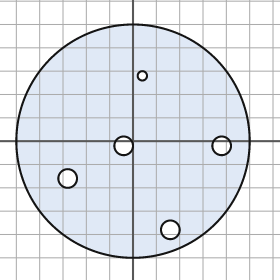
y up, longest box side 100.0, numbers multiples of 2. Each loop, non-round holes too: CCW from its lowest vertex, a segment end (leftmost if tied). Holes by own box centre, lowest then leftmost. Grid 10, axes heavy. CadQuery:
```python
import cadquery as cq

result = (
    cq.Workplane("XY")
    .moveTo(0.0, 0.0)
    .circle(50.0)
    .moveTo(16.0, -38.0)
    .circle(4.0)
    .moveTo(-28.0, -16.0)
    .circle(4.0)
    .moveTo(-4.0, -2.0)
    .circle(4.0)
    .moveTo(38.0, -2.0)
    .circle(4.0)
    .moveTo(4.0, 28.0)
    .circle(2.0)
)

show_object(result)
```